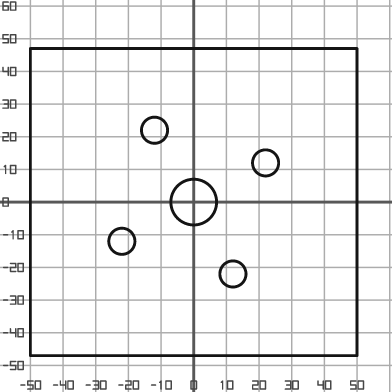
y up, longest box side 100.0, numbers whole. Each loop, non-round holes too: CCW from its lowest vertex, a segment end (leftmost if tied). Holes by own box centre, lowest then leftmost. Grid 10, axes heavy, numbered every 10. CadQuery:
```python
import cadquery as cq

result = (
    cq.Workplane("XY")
    .moveTo(-50.0, -47.0)
    .lineTo(50.0, -47.0)
    .lineTo(50.0, 47.0)
    .lineTo(-50.0, 47.0)
    .close()
    .moveTo(12.0, -22.0)
    .circle(4.0)
    .moveTo(-22.0, -12.0)
    .circle(4.0)
    .moveTo(0.0, 0.0)
    .circle(7.0)
    .moveTo(22.0, 12.0)
    .circle(4.0)
    .moveTo(-12.0, 22.0)
    .circle(4.0)
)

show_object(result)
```